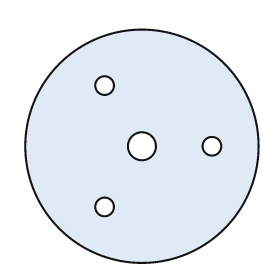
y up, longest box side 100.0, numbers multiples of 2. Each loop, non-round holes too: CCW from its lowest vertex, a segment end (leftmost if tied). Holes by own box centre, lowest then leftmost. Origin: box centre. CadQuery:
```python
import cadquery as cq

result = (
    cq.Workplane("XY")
    .moveTo(0.0, 0.0)
    .circle(50.0)
    .moveTo(-16.0, -26.0)
    .circle(4.0)
    .moveTo(0.0, 0.0)
    .circle(6.0)
    .moveTo(30.0, 0.0)
    .circle(4.0)
    .moveTo(-16.0, 26.0)
    .circle(4.0)
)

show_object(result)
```